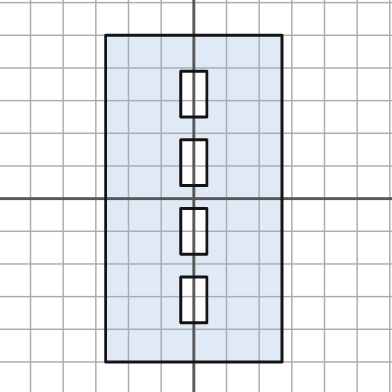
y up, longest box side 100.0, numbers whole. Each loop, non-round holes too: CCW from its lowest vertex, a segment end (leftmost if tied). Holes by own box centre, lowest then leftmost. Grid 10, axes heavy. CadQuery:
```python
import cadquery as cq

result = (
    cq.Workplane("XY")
    .moveTo(-27.0, -50.0)
    .lineTo(27.0, -50.0)
    .lineTo(27.0, 50.0)
    .lineTo(-27.0, 50.0)
    .close()
    .moveTo(-4.0, -38.0)
    .lineTo(4.0, -38.0)
    .lineTo(4.0, -24.0)
    .lineTo(-4.0, -24.0)
    .close()
    .moveTo(-4.0, -17.0)
    .lineTo(4.0, -17.0)
    .lineTo(4.0, -3.0)
    .lineTo(-4.0, -3.0)
    .close()
    .moveTo(-4.0, 4.0)
    .lineTo(4.0, 4.0)
    .lineTo(4.0, 18.0)
    .lineTo(-4.0, 18.0)
    .close()
    .moveTo(-4.0, 25.0)
    .lineTo(4.0, 25.0)
    .lineTo(4.0, 39.0)
    .lineTo(-4.0, 39.0)
    .close()
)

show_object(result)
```